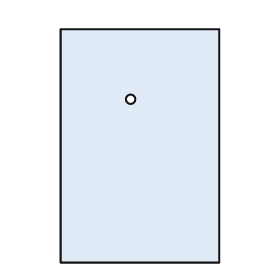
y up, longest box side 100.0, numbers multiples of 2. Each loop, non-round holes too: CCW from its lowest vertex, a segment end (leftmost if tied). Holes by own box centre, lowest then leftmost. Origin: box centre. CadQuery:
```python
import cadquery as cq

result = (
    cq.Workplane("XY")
    .moveTo(-34.0, -50.0)
    .lineTo(34.0, -50.0)
    .lineTo(34.0, 50.0)
    .lineTo(-34.0, 50.0)
    .close()
    .moveTo(-4.0, 20.0)
    .circle(2.0)
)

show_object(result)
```